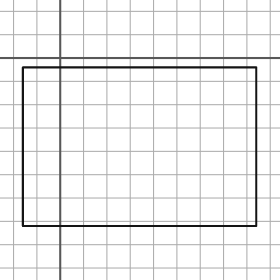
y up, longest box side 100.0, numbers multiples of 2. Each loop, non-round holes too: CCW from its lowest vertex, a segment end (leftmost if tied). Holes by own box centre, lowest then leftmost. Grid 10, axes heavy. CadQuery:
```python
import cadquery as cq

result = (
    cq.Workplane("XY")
    .moveTo(-16.0, -72.0)
    .lineTo(84.0, -72.0)
    .lineTo(84.0, -4.0)
    .lineTo(-16.0, -4.0)
    .close()
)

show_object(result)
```